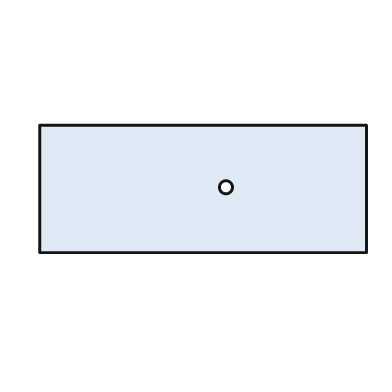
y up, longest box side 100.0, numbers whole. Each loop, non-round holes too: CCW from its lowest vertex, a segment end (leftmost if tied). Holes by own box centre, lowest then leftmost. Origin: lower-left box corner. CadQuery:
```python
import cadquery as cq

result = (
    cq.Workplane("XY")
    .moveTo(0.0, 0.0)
    .lineTo(100.0, 0.0)
    .lineTo(100.0, 39.0)
    .lineTo(0.0, 39.0)
    .close()
    .moveTo(57.0, 20.0)
    .circle(2.0)
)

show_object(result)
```